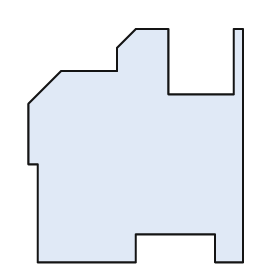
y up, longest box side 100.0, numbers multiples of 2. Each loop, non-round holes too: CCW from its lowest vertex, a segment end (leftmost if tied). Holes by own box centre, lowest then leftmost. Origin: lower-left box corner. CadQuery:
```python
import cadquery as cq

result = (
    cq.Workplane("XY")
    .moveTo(4.0, 0.0)
    .lineTo(46.0, 0.0)
    .lineTo(46.0, 12.0)
    .lineTo(80.0, 12.0)
    .lineTo(80.0, 0.0)
    .lineTo(92.0, 0.0)
    .lineTo(92.0, 100.0)
    .lineTo(88.0, 100.0)
    .lineTo(88.0, 72.0)
    .lineTo(60.0, 72.0)
    .lineTo(60.0, 100.0)
    .lineTo(46.0, 100.0)
    .lineTo(38.0, 92.0)
    .lineTo(38.0, 82.0)
    .lineTo(14.0, 82.0)
    .lineTo(0.0, 68.0)
    .lineTo(0.0, 42.0)
    .lineTo(4.0, 42.0)
    .close()
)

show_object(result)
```